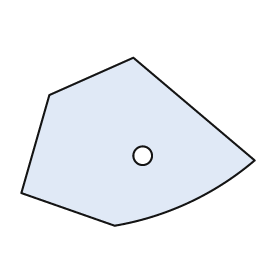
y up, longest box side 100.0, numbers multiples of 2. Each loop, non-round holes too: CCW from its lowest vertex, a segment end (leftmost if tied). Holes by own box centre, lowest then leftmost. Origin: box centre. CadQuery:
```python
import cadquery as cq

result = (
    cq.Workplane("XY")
    .moveTo(-10.0, -36.0)
    .threePointArc((22.0, -26.0), (50.0, -8.0))
    .lineTo(-2.0, 36.0)
    .lineTo(-38.0, 20.0)
    .lineTo(-50.0, -22.0)
    .close()
    .moveTo(2.0, -6.0)
    .circle(4.0)
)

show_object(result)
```